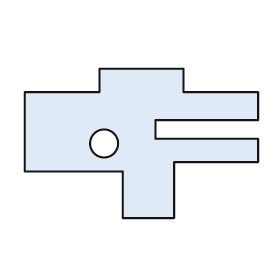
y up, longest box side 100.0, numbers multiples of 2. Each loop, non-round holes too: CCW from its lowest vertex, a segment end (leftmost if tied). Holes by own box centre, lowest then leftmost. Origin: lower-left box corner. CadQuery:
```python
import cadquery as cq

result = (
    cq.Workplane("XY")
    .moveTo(42.0, 0.0)
    .lineTo(64.0, 0.0)
    .lineTo(64.0, 24.0)
    .lineTo(100.0, 24.0)
    .lineTo(100.0, 34.0)
    .lineTo(56.0, 34.0)
    .lineTo(56.0, 42.0)
    .lineTo(100.0, 42.0)
    .lineTo(100.0, 54.0)
    .lineTo(68.0, 54.0)
    .lineTo(68.0, 64.0)
    .lineTo(32.0, 64.0)
    .lineTo(32.0, 54.0)
    .lineTo(0.0, 54.0)
    .lineTo(0.0, 20.0)
    .lineTo(42.0, 20.0)
    .close()
    .moveTo(34.0, 32.0)
    .circle(6.0)
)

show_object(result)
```